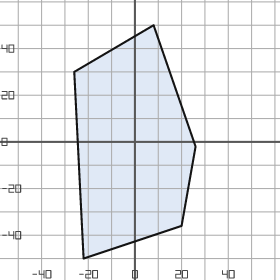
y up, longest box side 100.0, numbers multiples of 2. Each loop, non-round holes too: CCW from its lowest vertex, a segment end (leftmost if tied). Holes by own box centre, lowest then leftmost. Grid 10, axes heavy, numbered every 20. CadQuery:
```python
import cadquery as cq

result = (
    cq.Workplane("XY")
    .moveTo(-22.0, -50.0)
    .lineTo(20.0, -36.0)
    .lineTo(26.0, -2.0)
    .lineTo(8.0, 50.0)
    .lineTo(-26.0, 30.0)
    .close()
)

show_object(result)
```